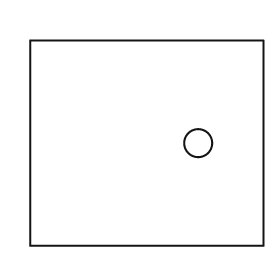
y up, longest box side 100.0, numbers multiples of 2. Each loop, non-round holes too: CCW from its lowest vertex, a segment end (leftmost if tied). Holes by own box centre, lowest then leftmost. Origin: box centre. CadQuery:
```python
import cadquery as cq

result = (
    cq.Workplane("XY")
    .moveTo(-50.0, -44.0)
    .lineTo(50.0, -44.0)
    .lineTo(50.0, 44.0)
    .lineTo(-50.0, 44.0)
    .close()
    .moveTo(22.0, 0.0)
    .circle(6.0)
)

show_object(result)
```